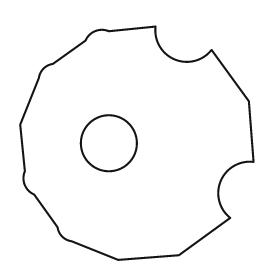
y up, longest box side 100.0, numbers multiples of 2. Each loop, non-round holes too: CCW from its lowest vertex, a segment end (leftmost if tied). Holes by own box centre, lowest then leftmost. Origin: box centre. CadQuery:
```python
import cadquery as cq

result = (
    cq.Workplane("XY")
    .moveTo(-8.0, -50.0)
    .lineTo(18.0, -48.0)
    .lineTo(40.0, -32.0)
    .threePointArc((36.0, -16.0), (50.0, -8.0))
    .lineTo(48.0, 18.0)
    .lineTo(32.0, 40.0)
    .threePointArc((16.0, 36.0), (8.0, 50.0))
    .lineTo(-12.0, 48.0)
    .threePointArc((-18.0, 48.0), (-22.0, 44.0))
    .lineTo(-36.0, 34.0)
    .threePointArc((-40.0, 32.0), (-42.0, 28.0))
    .lineTo(-50.0, 8.0)
    .lineTo(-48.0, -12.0)
    .threePointArc((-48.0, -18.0), (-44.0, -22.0))
    .lineTo(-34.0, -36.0)
    .threePointArc((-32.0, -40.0), (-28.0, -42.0))
    .close()
    .moveTo(-12.0, 0.0)
    .circle(12.0)
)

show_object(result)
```